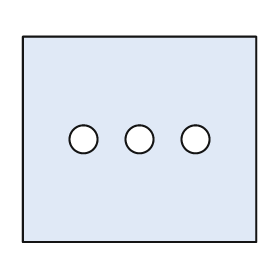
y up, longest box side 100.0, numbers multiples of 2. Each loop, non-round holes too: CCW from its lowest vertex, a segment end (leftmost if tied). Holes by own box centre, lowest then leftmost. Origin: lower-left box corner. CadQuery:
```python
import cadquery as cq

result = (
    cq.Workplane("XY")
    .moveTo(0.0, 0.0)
    .lineTo(100.0, 0.0)
    .lineTo(100.0, 88.0)
    .lineTo(0.0, 88.0)
    .close()
    .moveTo(26.0, 44.0)
    .circle(6.0)
    .moveTo(50.0, 44.0)
    .circle(6.0)
    .moveTo(74.0, 44.0)
    .circle(6.0)
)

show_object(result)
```